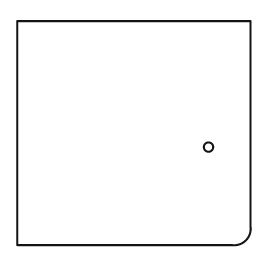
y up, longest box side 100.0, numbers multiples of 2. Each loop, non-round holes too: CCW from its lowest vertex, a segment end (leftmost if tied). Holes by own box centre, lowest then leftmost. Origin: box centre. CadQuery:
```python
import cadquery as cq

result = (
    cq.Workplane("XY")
    .moveTo(-50.0, -48.0)
    .lineTo(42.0, -48.0)
    .threePointArc((48.0, -46.0), (50.0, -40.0))
    .lineTo(50.0, 48.0)
    .lineTo(-50.0, 48.0)
    .close()
    .moveTo(32.0, -6.0)
    .circle(2.0)
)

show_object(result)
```